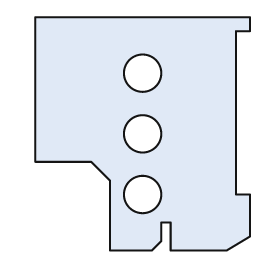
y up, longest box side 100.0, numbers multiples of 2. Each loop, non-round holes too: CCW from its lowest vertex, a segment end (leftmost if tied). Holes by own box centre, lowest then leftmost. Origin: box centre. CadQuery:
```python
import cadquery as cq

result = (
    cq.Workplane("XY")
    .moveTo(-14.0, -50.0)
    .lineTo(4.0, -50.0)
    .lineTo(8.0, -46.0)
    .lineTo(8.0, -38.0)
    .lineTo(12.0, -38.0)
    .lineTo(12.0, -50.0)
    .lineTo(36.0, -50.0)
    .lineTo(46.0, -44.0)
    .lineTo(46.0, -26.0)
    .lineTo(40.0, -26.0)
    .lineTo(40.0, 44.0)
    .lineTo(46.0, 44.0)
    .lineTo(46.0, 50.0)
    .lineTo(-46.0, 50.0)
    .lineTo(-46.0, -12.0)
    .lineTo(-22.0, -12.0)
    .lineTo(-14.0, -20.0)
    .close()
    .moveTo(0.0, -26.0)
    .circle(8.0)
    .moveTo(0.0, 0.0)
    .circle(8.0)
    .moveTo(0.0, 26.0)
    .circle(8.0)
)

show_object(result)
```